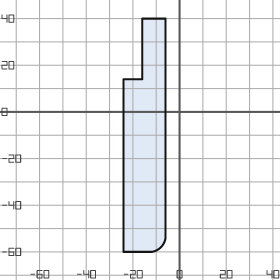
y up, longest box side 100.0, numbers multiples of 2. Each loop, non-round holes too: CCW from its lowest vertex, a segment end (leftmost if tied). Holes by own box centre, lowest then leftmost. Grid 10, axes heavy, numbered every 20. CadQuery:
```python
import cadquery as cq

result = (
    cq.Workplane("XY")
    .moveTo(-24.0, -60.0)
    .lineTo(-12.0, -60.0)
    .threePointArc((-8.0, -58.0), (-6.0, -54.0))
    .lineTo(-6.0, 40.0)
    .lineTo(-16.0, 40.0)
    .lineTo(-16.0, 14.0)
    .lineTo(-24.0, 14.0)
    .close()
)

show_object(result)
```